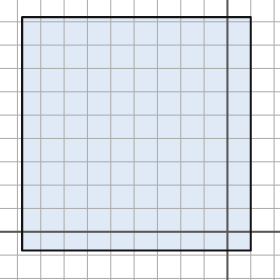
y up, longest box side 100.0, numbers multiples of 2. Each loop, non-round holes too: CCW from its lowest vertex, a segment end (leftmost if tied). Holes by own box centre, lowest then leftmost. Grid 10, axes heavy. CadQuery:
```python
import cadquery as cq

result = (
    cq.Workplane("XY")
    .moveTo(-88.0, -8.0)
    .lineTo(10.0, -8.0)
    .lineTo(10.0, 92.0)
    .lineTo(-88.0, 92.0)
    .close()
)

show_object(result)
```